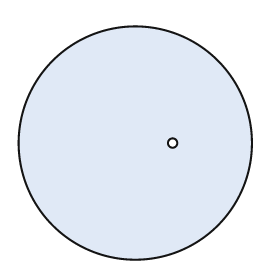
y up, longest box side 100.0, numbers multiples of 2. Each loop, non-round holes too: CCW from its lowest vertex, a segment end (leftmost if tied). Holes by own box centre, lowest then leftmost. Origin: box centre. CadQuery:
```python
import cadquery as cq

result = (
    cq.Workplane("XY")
    .moveTo(0.0, 0.0)
    .circle(50.0)
    .moveTo(16.0, 0.0)
    .circle(2.0)
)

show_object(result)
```